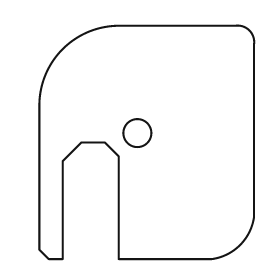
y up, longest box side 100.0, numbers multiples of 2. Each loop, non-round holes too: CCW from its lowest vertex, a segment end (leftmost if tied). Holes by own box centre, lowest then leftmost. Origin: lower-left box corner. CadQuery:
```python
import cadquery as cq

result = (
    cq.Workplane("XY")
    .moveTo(4.0, 0.0)
    .lineTo(10.0, 0.0)
    .lineTo(10.0, 42.0)
    .lineTo(18.0, 50.0)
    .lineTo(28.0, 50.0)
    .lineTo(34.0, 44.0)
    .lineTo(34.0, 0.0)
    .lineTo(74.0, 0.0)
    .threePointArc((86.0, 6.0), (92.0, 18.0))
    .lineTo(92.0, 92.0)
    .threePointArc((90.0, 98.0), (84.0, 100.0))
    .lineTo(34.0, 100.0)
    .threePointArc((10.0, 90.0), (0.0, 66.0))
    .lineTo(0.0, 4.0)
    .close()
    .moveTo(42.0, 54.0)
    .circle(6.0)
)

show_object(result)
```